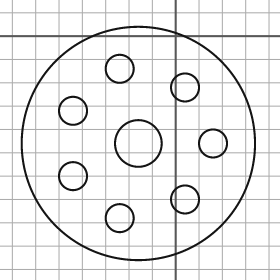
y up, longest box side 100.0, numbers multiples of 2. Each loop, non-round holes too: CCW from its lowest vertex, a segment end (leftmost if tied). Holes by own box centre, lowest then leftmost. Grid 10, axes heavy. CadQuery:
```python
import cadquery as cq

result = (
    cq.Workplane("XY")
    .moveTo(-16.0, -46.0)
    .circle(50.0)
    .moveTo(-24.0, -78.0)
    .circle(6.0)
    .moveTo(4.0, -70.0)
    .circle(6.0)
    .moveTo(-44.0, -60.0)
    .circle(6.0)
    .moveTo(-16.0, -46.0)
    .circle(10.0)
    .moveTo(16.0, -46.0)
    .circle(6.0)
    .moveTo(-44.0, -32.0)
    .circle(6.0)
    .moveTo(4.0, -22.0)
    .circle(6.0)
    .moveTo(-24.0, -14.0)
    .circle(6.0)
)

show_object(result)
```